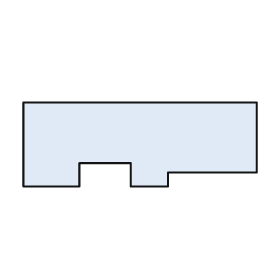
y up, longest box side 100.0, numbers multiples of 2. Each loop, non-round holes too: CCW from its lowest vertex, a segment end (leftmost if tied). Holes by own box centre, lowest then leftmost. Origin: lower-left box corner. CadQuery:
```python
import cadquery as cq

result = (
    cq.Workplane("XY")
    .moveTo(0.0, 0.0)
    .lineTo(24.0, 0.0)
    .lineTo(24.0, 10.0)
    .lineTo(46.0, 10.0)
    .lineTo(46.0, 0.0)
    .lineTo(62.0, 0.0)
    .lineTo(62.0, 6.0)
    .lineTo(100.0, 6.0)
    .lineTo(100.0, 36.0)
    .lineTo(0.0, 36.0)
    .close()
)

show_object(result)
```